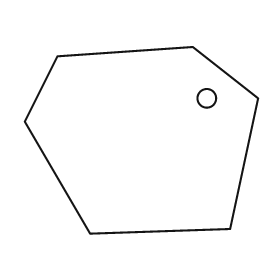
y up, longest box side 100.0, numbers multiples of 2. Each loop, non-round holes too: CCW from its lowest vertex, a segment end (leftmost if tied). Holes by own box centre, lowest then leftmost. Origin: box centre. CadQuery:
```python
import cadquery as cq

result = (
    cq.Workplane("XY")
    .moveTo(-22.0, -40.0)
    .lineTo(38.0, -38.0)
    .lineTo(50.0, 18.0)
    .lineTo(22.0, 40.0)
    .lineTo(-36.0, 36.0)
    .lineTo(-50.0, 8.0)
    .close()
    .moveTo(28.0, 18.0)
    .circle(4.0)
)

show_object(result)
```